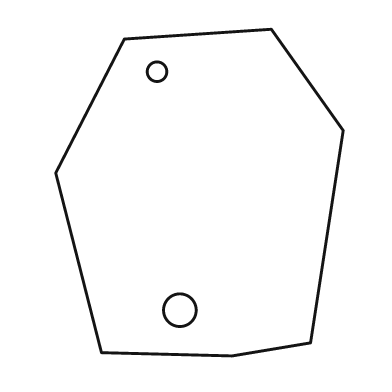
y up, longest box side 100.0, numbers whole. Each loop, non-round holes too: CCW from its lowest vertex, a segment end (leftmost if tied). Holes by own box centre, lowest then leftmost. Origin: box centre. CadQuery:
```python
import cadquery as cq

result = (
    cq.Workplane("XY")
    .moveTo(10.0, -50.0)
    .lineTo(34.0, -46.0)
    .lineTo(44.0, 19.0)
    .lineTo(22.0, 50.0)
    .lineTo(-23.0, 47.0)
    .lineTo(-44.0, 6.0)
    .lineTo(-30.0, -49.0)
    .close()
    .moveTo(-6.0, -36.0)
    .circle(5.0)
    .moveTo(-13.0, 37.0)
    .circle(3.0)
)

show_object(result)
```